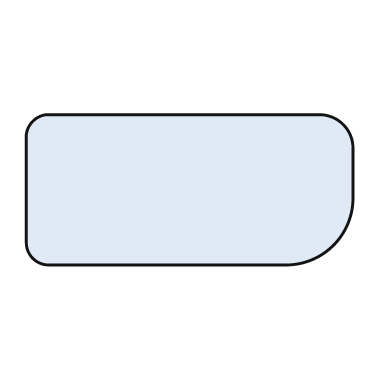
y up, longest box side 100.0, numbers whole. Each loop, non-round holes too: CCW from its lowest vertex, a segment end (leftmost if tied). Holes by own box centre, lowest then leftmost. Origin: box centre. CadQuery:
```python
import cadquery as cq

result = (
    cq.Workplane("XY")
    .moveTo(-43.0, -23.0)
    .lineTo(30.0, -23.0)
    .threePointArc((44.0, -17.0), (50.0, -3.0))
    .lineTo(50.0, 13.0)
    .threePointArc((47.0, 20.0), (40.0, 23.0))
    .lineTo(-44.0, 23.0)
    .threePointArc((-48.0, 21.0), (-50.0, 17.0))
    .lineTo(-50.0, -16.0)
    .threePointArc((-48.0, -21.0), (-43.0, -23.0))
    .close()
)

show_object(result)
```